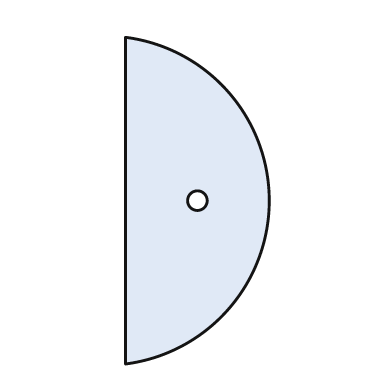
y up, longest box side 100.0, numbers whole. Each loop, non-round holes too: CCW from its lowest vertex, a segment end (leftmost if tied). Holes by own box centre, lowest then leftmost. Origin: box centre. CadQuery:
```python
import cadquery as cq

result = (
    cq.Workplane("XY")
    .moveTo(-22.0, -50.0)
    .threePointArc((22.0, 0.0), (-22.0, 50.0))
    .close()
    .moveTo(0.0, 0.0)
    .circle(3.0)
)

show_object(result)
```